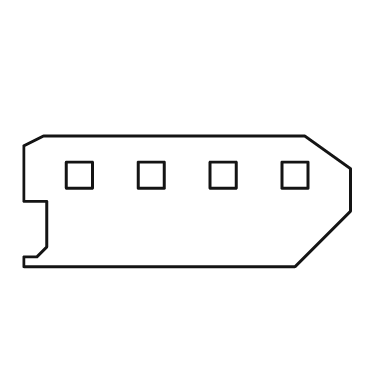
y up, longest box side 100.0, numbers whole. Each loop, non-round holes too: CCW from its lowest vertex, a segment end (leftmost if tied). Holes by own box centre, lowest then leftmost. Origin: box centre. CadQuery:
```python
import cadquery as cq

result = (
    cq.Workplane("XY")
    .moveTo(-50.0, -20.0)
    .lineTo(33.0, -20.0)
    .lineTo(50.0, -3.0)
    .lineTo(50.0, 10.0)
    .lineTo(36.0, 20.0)
    .lineTo(-44.0, 20.0)
    .lineTo(-50.0, 17.0)
    .lineTo(-50.0, 0.0)
    .lineTo(-43.0, 0.0)
    .lineTo(-43.0, -14.0)
    .lineTo(-46.0, -17.0)
    .lineTo(-50.0, -17.0)
    .close()
    .moveTo(-37.0, 4.0)
    .lineTo(-29.0, 4.0)
    .lineTo(-29.0, 12.0)
    .lineTo(-37.0, 12.0)
    .close()
    .moveTo(-15.0, 4.0)
    .lineTo(-7.0, 4.0)
    .lineTo(-7.0, 12.0)
    .lineTo(-15.0, 12.0)
    .close()
    .moveTo(7.0, 4.0)
    .lineTo(15.0, 4.0)
    .lineTo(15.0, 12.0)
    .lineTo(7.0, 12.0)
    .close()
    .moveTo(29.0, 4.0)
    .lineTo(37.0, 4.0)
    .lineTo(37.0, 12.0)
    .lineTo(29.0, 12.0)
    .close()
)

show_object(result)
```